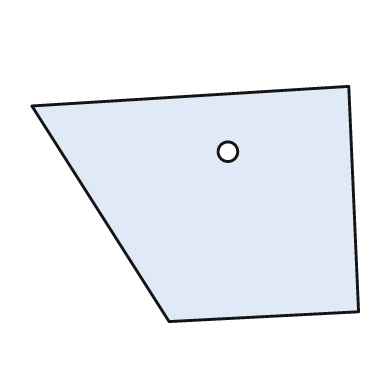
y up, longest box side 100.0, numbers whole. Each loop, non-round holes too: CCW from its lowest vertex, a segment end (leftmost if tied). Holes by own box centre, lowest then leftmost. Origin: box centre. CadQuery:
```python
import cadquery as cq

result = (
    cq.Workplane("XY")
    .moveTo(-8.0, -36.0)
    .lineTo(50.0, -33.0)
    .lineTo(47.0, 36.0)
    .lineTo(-50.0, 30.0)
    .close()
    .moveTo(10.0, 16.0)
    .circle(3.0)
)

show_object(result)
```